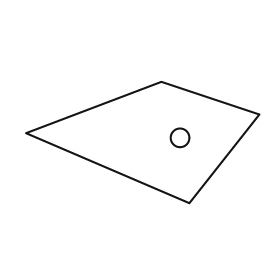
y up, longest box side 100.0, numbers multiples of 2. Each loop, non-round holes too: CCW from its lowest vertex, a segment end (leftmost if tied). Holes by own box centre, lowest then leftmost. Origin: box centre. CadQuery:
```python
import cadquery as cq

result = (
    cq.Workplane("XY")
    .moveTo(20.0, -26.0)
    .lineTo(50.0, 12.0)
    .lineTo(8.0, 26.0)
    .lineTo(-50.0, 4.0)
    .close()
    .moveTo(16.0, 2.0)
    .circle(4.0)
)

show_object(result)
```